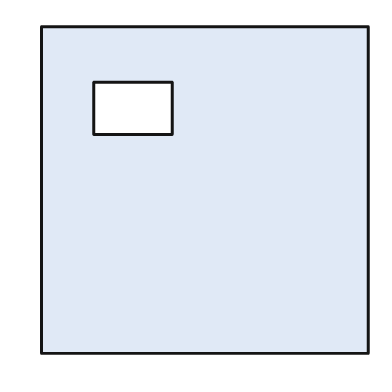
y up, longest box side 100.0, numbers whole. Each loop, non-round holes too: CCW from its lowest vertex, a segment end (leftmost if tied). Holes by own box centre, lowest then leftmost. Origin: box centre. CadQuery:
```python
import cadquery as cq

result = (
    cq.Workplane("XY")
    .moveTo(-50.0, -50.0)
    .lineTo(50.0, -50.0)
    .lineTo(50.0, 50.0)
    .lineTo(-50.0, 50.0)
    .close()
    .moveTo(-34.0, 17.0)
    .lineTo(-10.0, 17.0)
    .lineTo(-10.0, 33.0)
    .lineTo(-34.0, 33.0)
    .close()
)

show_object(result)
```